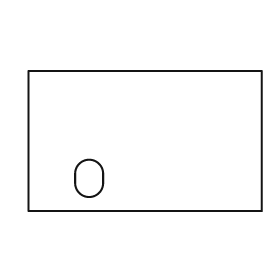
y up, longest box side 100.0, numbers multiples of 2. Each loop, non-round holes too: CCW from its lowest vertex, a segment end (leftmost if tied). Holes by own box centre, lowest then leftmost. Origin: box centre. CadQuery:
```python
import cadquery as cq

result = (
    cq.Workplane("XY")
    .moveTo(-50.0, -30.0)
    .lineTo(50.0, -30.0)
    .lineTo(50.0, 30.0)
    .lineTo(-50.0, 30.0)
    .close()
    .moveTo(-30.0, -18.0)
    .threePointArc((-24.0, -24.0), (-18.0, -18.0))
    .lineTo(-18.0, -14.0)
    .threePointArc((-24.0, -8.0), (-30.0, -14.0))
    .close()
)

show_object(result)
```